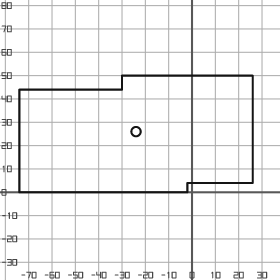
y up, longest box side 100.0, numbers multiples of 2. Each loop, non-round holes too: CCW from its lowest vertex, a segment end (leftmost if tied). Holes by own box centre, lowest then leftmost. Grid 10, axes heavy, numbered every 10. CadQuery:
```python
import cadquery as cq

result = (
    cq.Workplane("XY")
    .moveTo(-74.0, 0.0)
    .lineTo(-2.0, 0.0)
    .lineTo(-2.0, 4.0)
    .lineTo(26.0, 4.0)
    .lineTo(26.0, 50.0)
    .lineTo(-30.0, 50.0)
    .lineTo(-30.0, 44.0)
    .lineTo(-74.0, 44.0)
    .close()
    .moveTo(-24.0, 26.0)
    .circle(2.0)
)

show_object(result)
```